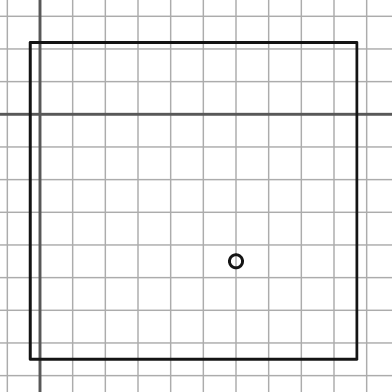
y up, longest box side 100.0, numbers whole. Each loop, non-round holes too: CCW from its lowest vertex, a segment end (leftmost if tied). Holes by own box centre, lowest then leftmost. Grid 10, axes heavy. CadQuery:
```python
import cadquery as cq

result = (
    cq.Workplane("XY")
    .moveTo(-3.0, -75.0)
    .lineTo(97.0, -75.0)
    .lineTo(97.0, 22.0)
    .lineTo(-3.0, 22.0)
    .close()
    .moveTo(60.0, -45.0)
    .circle(2.0)
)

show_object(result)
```